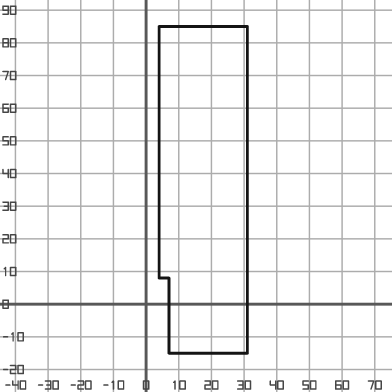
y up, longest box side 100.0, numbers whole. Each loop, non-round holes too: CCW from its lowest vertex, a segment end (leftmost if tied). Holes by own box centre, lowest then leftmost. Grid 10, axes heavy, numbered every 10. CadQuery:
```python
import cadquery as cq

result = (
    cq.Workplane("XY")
    .moveTo(7.0, -15.0)
    .lineTo(31.0, -15.0)
    .lineTo(31.0, 85.0)
    .lineTo(4.0, 85.0)
    .lineTo(4.0, 8.0)
    .lineTo(7.0, 8.0)
    .close()
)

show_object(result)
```